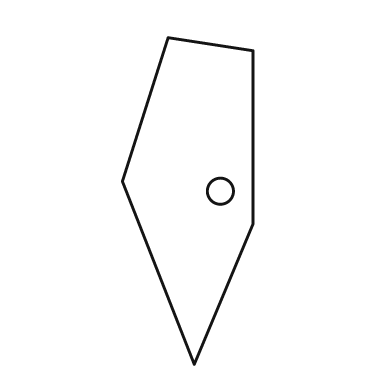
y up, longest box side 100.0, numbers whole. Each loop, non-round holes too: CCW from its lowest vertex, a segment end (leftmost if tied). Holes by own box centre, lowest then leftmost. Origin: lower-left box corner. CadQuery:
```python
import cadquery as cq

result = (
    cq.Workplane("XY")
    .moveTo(22.0, 0.0)
    .lineTo(40.0, 43.0)
    .lineTo(40.0, 96.0)
    .lineTo(14.0, 100.0)
    .lineTo(0.0, 56.0)
    .close()
    .moveTo(30.0, 53.0)
    .circle(4.0)
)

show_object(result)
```